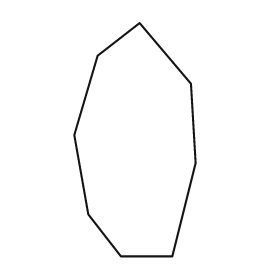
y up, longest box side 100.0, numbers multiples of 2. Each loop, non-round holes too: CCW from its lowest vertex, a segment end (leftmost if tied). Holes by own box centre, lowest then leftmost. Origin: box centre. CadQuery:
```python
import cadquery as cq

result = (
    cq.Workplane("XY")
    .moveTo(-6.0, -50.0)
    .lineTo(16.0, -50.0)
    .lineTo(26.0, -10.0)
    .lineTo(24.0, 24.0)
    .lineTo(2.0, 50.0)
    .lineTo(-16.0, 36.0)
    .lineTo(-26.0, 2.0)
    .lineTo(-20.0, -32.0)
    .close()
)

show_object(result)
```